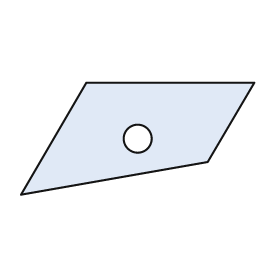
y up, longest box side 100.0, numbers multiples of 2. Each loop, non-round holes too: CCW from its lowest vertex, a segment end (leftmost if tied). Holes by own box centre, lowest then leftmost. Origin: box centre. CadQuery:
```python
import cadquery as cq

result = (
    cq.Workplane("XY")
    .moveTo(-50.0, -24.0)
    .lineTo(30.0, -10.0)
    .lineTo(50.0, 24.0)
    .lineTo(-22.0, 24.0)
    .close()
    .moveTo(0.0, 0.0)
    .circle(6.0)
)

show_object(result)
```